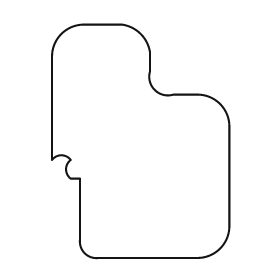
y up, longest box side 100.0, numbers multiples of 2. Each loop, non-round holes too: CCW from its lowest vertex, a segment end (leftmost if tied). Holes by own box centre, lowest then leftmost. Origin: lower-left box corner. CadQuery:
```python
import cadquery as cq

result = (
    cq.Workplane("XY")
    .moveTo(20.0, 0.0)
    .lineTo(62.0, 0.0)
    .threePointArc((72.0, 4.0), (76.0, 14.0))
    .lineTo(76.0, 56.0)
    .threePointArc((72.0, 66.0), (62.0, 70.0))
    .lineTo(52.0, 70.0)
    .threePointArc((44.0, 72.0), (42.0, 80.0))
    .lineTo(42.0, 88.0)
    .threePointArc((38.0, 96.0), (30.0, 100.0))
    .lineTo(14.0, 100.0)
    .threePointArc((4.0, 96.0), (0.0, 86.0))
    .lineTo(0.0, 42.0)
    .threePointArc((4.0, 44.0), (8.0, 42.0))
    .threePointArc((6.0, 38.0), (8.0, 34.0))
    .lineTo(12.0, 34.0)
    .lineTo(12.0, 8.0)
    .threePointArc((14.0, 2.0), (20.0, 0.0))
    .close()
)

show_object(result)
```